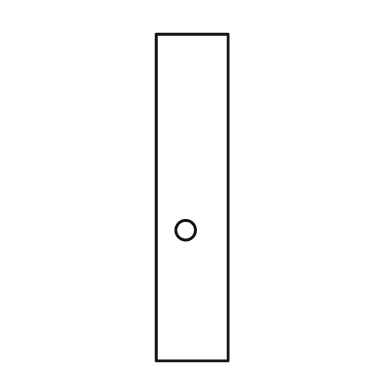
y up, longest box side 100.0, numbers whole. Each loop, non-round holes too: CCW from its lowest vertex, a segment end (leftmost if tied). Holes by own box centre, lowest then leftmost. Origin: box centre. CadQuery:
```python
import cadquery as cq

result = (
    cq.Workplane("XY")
    .moveTo(-11.0, -50.0)
    .lineTo(11.0, -50.0)
    .lineTo(11.0, 50.0)
    .lineTo(-11.0, 50.0)
    .close()
    .moveTo(-2.0, -10.0)
    .circle(3.0)
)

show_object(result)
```